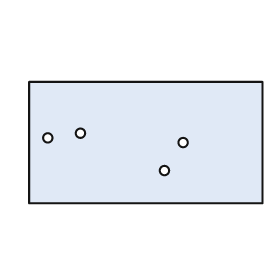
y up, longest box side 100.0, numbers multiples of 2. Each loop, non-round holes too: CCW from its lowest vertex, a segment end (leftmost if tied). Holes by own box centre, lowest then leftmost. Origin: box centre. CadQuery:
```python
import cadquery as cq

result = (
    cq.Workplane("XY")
    .moveTo(-50.0, -26.0)
    .lineTo(50.0, -26.0)
    .lineTo(50.0, 26.0)
    .lineTo(-50.0, 26.0)
    .close()
    .moveTo(8.0, -12.0)
    .circle(2.0)
    .moveTo(16.0, 0.0)
    .circle(2.0)
    .moveTo(-42.0, 2.0)
    .circle(2.0)
    .moveTo(-28.0, 4.0)
    .circle(2.0)
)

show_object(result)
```